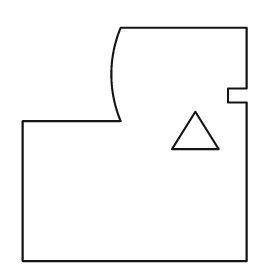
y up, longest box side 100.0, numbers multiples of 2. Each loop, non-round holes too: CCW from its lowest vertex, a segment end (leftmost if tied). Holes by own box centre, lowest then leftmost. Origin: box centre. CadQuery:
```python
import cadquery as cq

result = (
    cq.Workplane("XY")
    .moveTo(-48.0, -50.0)
    .lineTo(48.0, -50.0)
    .lineTo(48.0, 18.0)
    .lineTo(40.0, 18.0)
    .lineTo(40.0, 24.0)
    .lineTo(48.0, 24.0)
    .lineTo(48.0, 50.0)
    .lineTo(-6.0, 50.0)
    .threePointArc((-10.0, 30.0), (-6.0, 10.0))
    .lineTo(-48.0, 10.0)
    .close()
    .moveTo(16.0, -2.0)
    .lineTo(36.0, -2.0)
    .lineTo(26.0, 14.0)
    .close()
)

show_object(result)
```